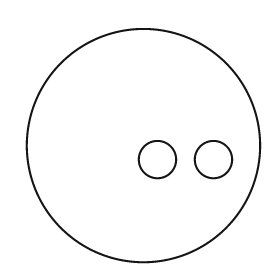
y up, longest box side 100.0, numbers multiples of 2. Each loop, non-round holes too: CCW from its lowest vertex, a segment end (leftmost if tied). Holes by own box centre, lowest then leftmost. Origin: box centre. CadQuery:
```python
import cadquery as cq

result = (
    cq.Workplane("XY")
    .moveTo(0.0, 0.0)
    .circle(50.0)
    .moveTo(6.0, -6.0)
    .circle(8.0)
    .moveTo(30.0, -6.0)
    .circle(8.0)
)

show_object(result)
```